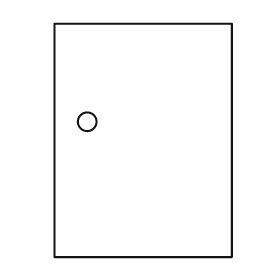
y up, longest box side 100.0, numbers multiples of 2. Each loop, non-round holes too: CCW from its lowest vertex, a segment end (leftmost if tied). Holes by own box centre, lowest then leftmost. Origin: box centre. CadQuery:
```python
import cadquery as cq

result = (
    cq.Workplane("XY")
    .moveTo(-38.0, -50.0)
    .lineTo(38.0, -50.0)
    .lineTo(38.0, 50.0)
    .lineTo(-38.0, 50.0)
    .close()
    .moveTo(-24.0, 8.0)
    .circle(4.0)
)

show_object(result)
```